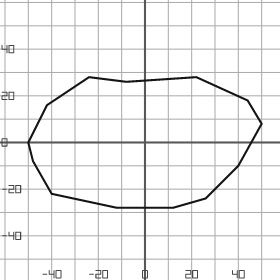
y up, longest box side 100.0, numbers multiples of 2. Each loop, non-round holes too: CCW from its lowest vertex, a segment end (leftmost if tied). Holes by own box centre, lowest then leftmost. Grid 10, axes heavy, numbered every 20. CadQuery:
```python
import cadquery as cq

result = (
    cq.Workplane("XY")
    .moveTo(-12.0, -28.0)
    .lineTo(12.0, -28.0)
    .lineTo(26.0, -24.0)
    .lineTo(40.0, -10.0)
    .lineTo(50.0, 8.0)
    .lineTo(44.0, 18.0)
    .lineTo(22.0, 28.0)
    .lineTo(-8.0, 26.0)
    .lineTo(-24.0, 28.0)
    .lineTo(-42.0, 16.0)
    .lineTo(-50.0, 0.0)
    .lineTo(-48.0, -8.0)
    .lineTo(-40.0, -22.0)
    .close()
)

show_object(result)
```